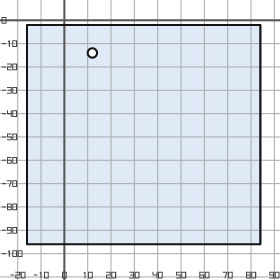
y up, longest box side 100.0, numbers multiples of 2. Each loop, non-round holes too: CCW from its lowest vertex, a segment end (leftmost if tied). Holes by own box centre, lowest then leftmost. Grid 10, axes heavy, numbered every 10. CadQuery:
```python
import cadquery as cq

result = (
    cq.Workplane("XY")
    .moveTo(-16.0, -96.0)
    .lineTo(84.0, -96.0)
    .lineTo(84.0, -2.0)
    .lineTo(-16.0, -2.0)
    .close()
    .moveTo(12.0, -14.0)
    .circle(2.0)
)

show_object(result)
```